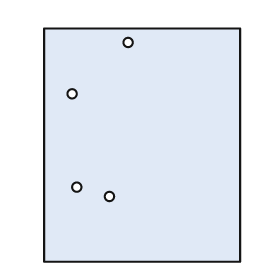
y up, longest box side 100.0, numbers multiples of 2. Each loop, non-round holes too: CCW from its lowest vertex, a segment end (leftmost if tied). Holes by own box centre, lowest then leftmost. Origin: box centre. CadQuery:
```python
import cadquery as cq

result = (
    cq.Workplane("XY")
    .moveTo(-42.0, -50.0)
    .lineTo(42.0, -50.0)
    .lineTo(42.0, 50.0)
    .lineTo(-42.0, 50.0)
    .close()
    .moveTo(-14.0, -22.0)
    .circle(2.0)
    .moveTo(-28.0, -18.0)
    .circle(2.0)
    .moveTo(-30.0, 22.0)
    .circle(2.0)
    .moveTo(-6.0, 44.0)
    .circle(2.0)
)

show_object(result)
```